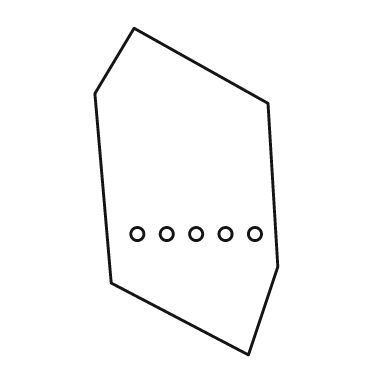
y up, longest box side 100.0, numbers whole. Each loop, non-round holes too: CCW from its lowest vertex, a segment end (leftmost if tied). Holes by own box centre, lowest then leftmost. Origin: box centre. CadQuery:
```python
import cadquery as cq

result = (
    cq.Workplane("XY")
    .moveTo(19.0, -50.0)
    .lineTo(28.0, -23.0)
    .lineTo(25.0, 27.0)
    .lineTo(-16.0, 50.0)
    .lineTo(-28.0, 30.0)
    .lineTo(-23.0, -28.0)
    .close()
    .moveTo(-15.0, -13.0)
    .circle(2.0)
    .moveTo(-6.0, -13.0)
    .circle(2.0)
    .moveTo(3.0, -13.0)
    .circle(2.0)
    .moveTo(12.0, -13.0)
    .circle(2.0)
    .moveTo(21.0, -13.0)
    .circle(2.0)
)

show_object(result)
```